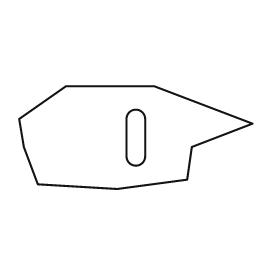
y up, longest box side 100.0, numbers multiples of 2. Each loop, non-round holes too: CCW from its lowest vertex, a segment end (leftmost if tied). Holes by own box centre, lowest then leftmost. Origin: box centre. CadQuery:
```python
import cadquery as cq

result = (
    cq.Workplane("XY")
    .moveTo(-8.0, -22.0)
    .lineTo(22.0, -18.0)
    .lineTo(24.0, -4.0)
    .lineTo(50.0, 6.0)
    .lineTo(8.0, 22.0)
    .lineTo(-30.0, 22.0)
    .lineTo(-50.0, 8.0)
    .lineTo(-48.0, -4.0)
    .lineTo(-42.0, -20.0)
    .close()
    .moveTo(-4.0, -8.0)
    .threePointArc((0.0, -12.0), (4.0, -8.0))
    .lineTo(4.0, 8.0)
    .threePointArc((0.0, 12.0), (-4.0, 8.0))
    .close()
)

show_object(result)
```